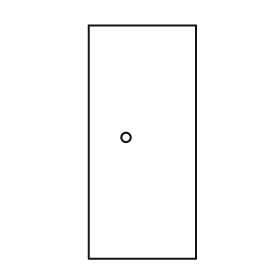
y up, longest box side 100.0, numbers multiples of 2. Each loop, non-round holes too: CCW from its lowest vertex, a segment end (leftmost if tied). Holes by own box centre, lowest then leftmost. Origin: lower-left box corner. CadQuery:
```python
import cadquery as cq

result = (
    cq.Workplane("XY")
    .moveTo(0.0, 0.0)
    .lineTo(46.0, 0.0)
    .lineTo(46.0, 100.0)
    .lineTo(0.0, 100.0)
    .close()
    .moveTo(16.0, 52.0)
    .circle(2.0)
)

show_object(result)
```